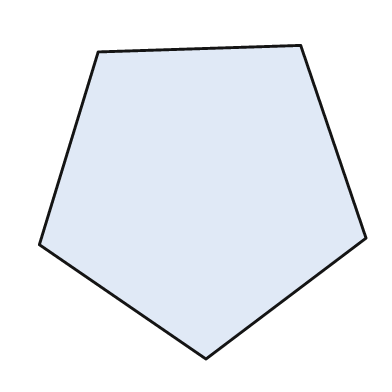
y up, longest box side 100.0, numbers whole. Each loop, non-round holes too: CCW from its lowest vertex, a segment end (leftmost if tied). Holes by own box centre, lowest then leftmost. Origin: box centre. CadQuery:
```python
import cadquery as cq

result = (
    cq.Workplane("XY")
    .moveTo(1.0, -48.0)
    .lineTo(50.0, -11.0)
    .lineTo(30.0, 48.0)
    .lineTo(-32.0, 46.0)
    .lineTo(-50.0, -13.0)
    .close()
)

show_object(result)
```